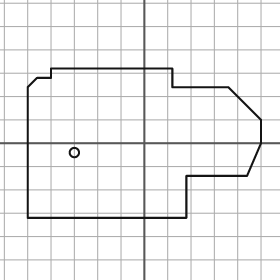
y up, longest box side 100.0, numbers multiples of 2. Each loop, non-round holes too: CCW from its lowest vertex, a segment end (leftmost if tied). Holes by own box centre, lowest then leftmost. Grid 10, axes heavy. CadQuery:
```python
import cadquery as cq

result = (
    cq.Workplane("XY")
    .moveTo(-50.0, -32.0)
    .lineTo(18.0, -32.0)
    .lineTo(18.0, -14.0)
    .lineTo(44.0, -14.0)
    .lineTo(50.0, 0.0)
    .lineTo(50.0, 10.0)
    .lineTo(36.0, 24.0)
    .lineTo(12.0, 24.0)
    .lineTo(12.0, 32.0)
    .lineTo(-40.0, 32.0)
    .lineTo(-40.0, 28.0)
    .lineTo(-46.0, 28.0)
    .lineTo(-50.0, 24.0)
    .close()
    .moveTo(-30.0, -4.0)
    .circle(2.0)
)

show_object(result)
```